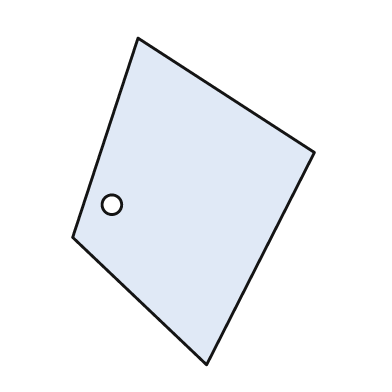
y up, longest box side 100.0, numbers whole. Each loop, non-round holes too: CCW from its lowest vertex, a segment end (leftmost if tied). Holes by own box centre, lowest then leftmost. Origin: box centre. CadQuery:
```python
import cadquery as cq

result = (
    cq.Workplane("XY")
    .moveTo(4.0, -50.0)
    .lineTo(37.0, 15.0)
    .lineTo(-17.0, 50.0)
    .lineTo(-37.0, -11.0)
    .close()
    .moveTo(-25.0, -1.0)
    .circle(3.0)
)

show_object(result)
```